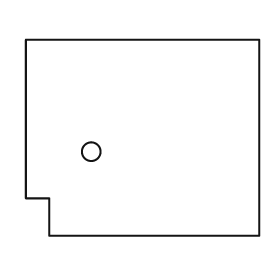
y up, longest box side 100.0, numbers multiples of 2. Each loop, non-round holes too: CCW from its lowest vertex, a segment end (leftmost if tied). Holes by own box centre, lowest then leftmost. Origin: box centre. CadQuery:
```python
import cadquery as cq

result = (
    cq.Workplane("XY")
    .moveTo(-40.0, -42.0)
    .lineTo(50.0, -42.0)
    .lineTo(50.0, 42.0)
    .lineTo(-50.0, 42.0)
    .lineTo(-50.0, -26.0)
    .lineTo(-40.0, -26.0)
    .close()
    .moveTo(-22.0, -6.0)
    .circle(4.0)
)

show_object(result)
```